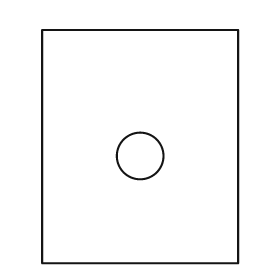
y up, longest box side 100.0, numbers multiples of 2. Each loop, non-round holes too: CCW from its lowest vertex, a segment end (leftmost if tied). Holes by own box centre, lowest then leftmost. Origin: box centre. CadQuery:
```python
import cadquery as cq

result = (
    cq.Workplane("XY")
    .moveTo(-42.0, -50.0)
    .lineTo(42.0, -50.0)
    .lineTo(42.0, 50.0)
    .lineTo(-42.0, 50.0)
    .close()
    .moveTo(0.0, -4.0)
    .circle(10.0)
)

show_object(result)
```